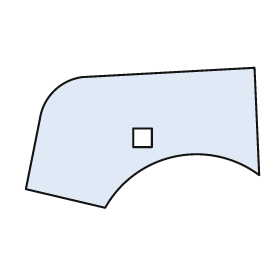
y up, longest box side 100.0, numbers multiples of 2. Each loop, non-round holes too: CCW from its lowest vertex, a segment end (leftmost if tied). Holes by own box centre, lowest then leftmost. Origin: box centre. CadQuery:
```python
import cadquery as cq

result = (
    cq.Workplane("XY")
    .moveTo(-16.0, -30.0)
    .threePointArc((14.0, -8.0), (50.0, -16.0))
    .lineTo(48.0, 30.0)
    .lineTo(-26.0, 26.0)
    .threePointArc((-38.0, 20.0), (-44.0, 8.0))
    .lineTo(-50.0, -22.0)
    .close()
    .moveTo(-4.0, -4.0)
    .lineTo(4.0, -4.0)
    .lineTo(4.0, 4.0)
    .lineTo(-4.0, 4.0)
    .close()
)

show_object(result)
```